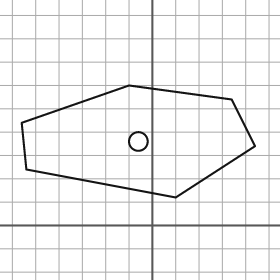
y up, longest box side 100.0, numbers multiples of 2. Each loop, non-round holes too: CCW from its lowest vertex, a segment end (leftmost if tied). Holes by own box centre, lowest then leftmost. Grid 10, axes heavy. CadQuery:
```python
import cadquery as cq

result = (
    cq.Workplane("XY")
    .moveTo(10.0, 12.0)
    .lineTo(44.0, 34.0)
    .lineTo(34.0, 54.0)
    .lineTo(-10.0, 60.0)
    .lineTo(-56.0, 44.0)
    .lineTo(-54.0, 24.0)
    .close()
    .moveTo(-6.0, 36.0)
    .circle(4.0)
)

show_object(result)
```